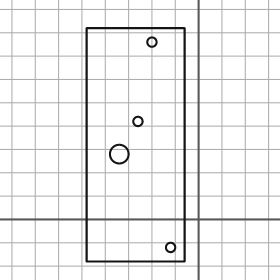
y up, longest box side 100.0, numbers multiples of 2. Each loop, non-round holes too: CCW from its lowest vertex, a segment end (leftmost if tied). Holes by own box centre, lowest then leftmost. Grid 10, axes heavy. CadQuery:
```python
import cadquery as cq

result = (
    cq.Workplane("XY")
    .moveTo(-48.0, -18.0)
    .lineTo(-6.0, -18.0)
    .lineTo(-6.0, 82.0)
    .lineTo(-48.0, 82.0)
    .close()
    .moveTo(-12.0, -12.0)
    .circle(2.0)
    .moveTo(-34.0, 28.0)
    .circle(4.0)
    .moveTo(-26.0, 42.0)
    .circle(2.0)
    .moveTo(-20.0, 76.0)
    .circle(2.0)
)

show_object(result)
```